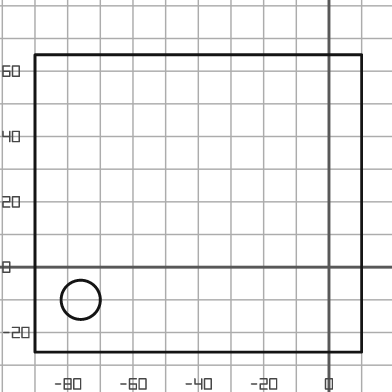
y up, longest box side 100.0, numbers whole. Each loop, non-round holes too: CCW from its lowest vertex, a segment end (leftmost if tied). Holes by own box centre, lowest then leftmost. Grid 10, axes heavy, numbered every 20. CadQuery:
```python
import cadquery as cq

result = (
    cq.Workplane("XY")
    .moveTo(-90.0, -26.0)
    .lineTo(10.0, -26.0)
    .lineTo(10.0, 65.0)
    .lineTo(-90.0, 65.0)
    .close()
    .moveTo(-76.0, -10.0)
    .circle(6.0)
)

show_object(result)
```